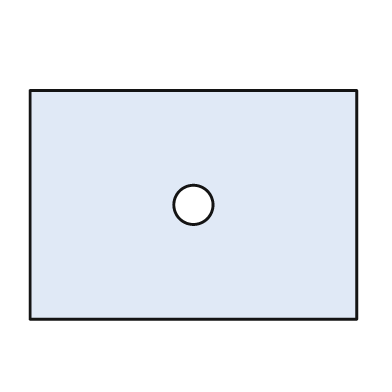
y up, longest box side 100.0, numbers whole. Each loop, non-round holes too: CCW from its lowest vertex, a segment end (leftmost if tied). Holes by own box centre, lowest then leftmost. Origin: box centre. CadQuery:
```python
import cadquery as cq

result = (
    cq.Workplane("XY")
    .moveTo(-50.0, -35.0)
    .lineTo(50.0, -35.0)
    .lineTo(50.0, 35.0)
    .lineTo(-50.0, 35.0)
    .close()
    .moveTo(0.0, 0.0)
    .circle(6.0)
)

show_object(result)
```